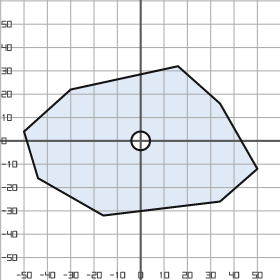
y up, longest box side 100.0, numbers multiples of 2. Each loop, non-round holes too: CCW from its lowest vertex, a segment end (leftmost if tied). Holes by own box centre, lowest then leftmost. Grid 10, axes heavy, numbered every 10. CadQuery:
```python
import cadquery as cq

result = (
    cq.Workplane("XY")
    .moveTo(-16.0, -32.0)
    .lineTo(34.0, -26.0)
    .lineTo(50.0, -12.0)
    .lineTo(34.0, 16.0)
    .lineTo(16.0, 32.0)
    .lineTo(-30.0, 22.0)
    .lineTo(-50.0, 4.0)
    .lineTo(-44.0, -16.0)
    .close()
    .moveTo(0.0, 0.0)
    .circle(4.0)
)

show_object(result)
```